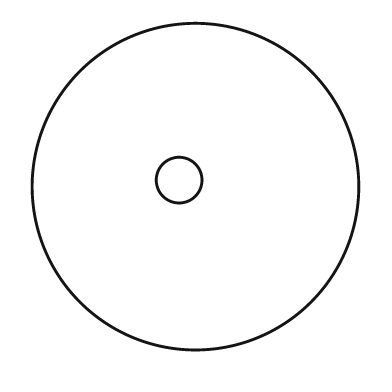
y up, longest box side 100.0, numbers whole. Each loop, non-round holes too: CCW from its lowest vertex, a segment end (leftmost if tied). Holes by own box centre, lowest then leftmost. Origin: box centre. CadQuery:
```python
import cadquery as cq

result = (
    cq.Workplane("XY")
    .moveTo(0.0, 0.0)
    .circle(50.0)
    .moveTo(-5.0, 2.0)
    .circle(7.0)
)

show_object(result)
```